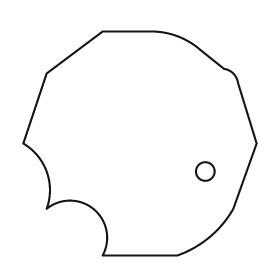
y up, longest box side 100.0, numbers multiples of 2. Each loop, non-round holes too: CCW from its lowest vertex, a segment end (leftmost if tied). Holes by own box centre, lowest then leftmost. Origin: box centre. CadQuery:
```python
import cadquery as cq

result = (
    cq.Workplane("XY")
    .moveTo(-16.0, -48.0)
    .lineTo(16.0, -48.0)
    .threePointArc((30.0, -40.0), (40.0, -28.0))
    .lineTo(50.0, 0.0)
    .lineTo(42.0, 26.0)
    .threePointArc((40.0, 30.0), (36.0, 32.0))
    .lineTo(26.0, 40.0)
    .threePointArc((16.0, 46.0), (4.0, 48.0))
    .lineTo(-16.0, 48.0)
    .lineTo(-40.0, 30.0)
    .lineTo(-50.0, 0.0)
    .threePointArc((-40.0, -12.0), (-40.0, -28.0))
    .threePointArc((-20.0, -28.0), (-16.0, -48.0))
    .close()
    .moveTo(28.0, -12.0)
    .circle(4.0)
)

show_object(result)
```